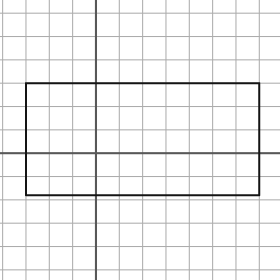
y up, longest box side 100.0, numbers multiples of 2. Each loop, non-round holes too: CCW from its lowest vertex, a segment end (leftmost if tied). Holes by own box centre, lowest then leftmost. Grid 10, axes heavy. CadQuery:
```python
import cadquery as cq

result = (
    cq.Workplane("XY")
    .moveTo(-30.0, -18.0)
    .lineTo(70.0, -18.0)
    .lineTo(70.0, 30.0)
    .lineTo(-30.0, 30.0)
    .close()
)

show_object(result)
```